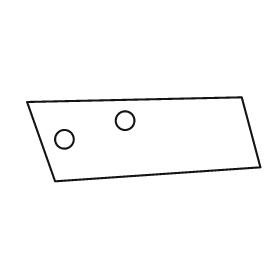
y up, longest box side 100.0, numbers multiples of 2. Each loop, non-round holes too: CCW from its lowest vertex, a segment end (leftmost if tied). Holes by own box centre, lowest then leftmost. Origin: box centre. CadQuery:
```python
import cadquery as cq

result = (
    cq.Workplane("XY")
    .moveTo(-38.0, -18.0)
    .lineTo(50.0, -12.0)
    .lineTo(42.0, 18.0)
    .lineTo(-50.0, 16.0)
    .close()
    .moveTo(-34.0, 0.0)
    .circle(4.0)
    .moveTo(-8.0, 8.0)
    .circle(4.0)
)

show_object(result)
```